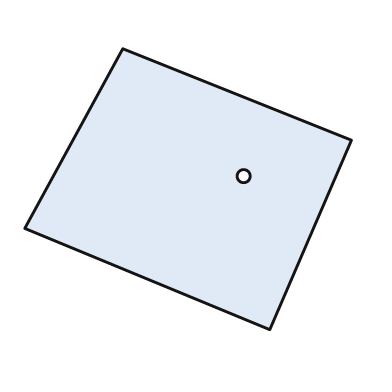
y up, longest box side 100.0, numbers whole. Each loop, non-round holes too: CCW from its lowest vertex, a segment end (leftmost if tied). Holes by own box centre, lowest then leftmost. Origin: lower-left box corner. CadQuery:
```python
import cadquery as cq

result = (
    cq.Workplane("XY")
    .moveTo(75.0, 0.0)
    .lineTo(100.0, 58.0)
    .lineTo(30.0, 86.0)
    .lineTo(0.0, 31.0)
    .close()
    .moveTo(67.0, 47.0)
    .circle(2.0)
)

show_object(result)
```